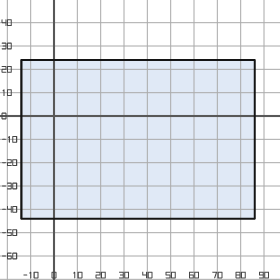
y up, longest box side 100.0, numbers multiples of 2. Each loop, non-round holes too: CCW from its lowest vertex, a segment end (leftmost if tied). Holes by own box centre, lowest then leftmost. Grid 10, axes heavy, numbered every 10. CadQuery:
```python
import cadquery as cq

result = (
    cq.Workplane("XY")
    .moveTo(-14.0, -44.0)
    .lineTo(86.0, -44.0)
    .lineTo(86.0, 24.0)
    .lineTo(-14.0, 24.0)
    .close()
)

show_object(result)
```